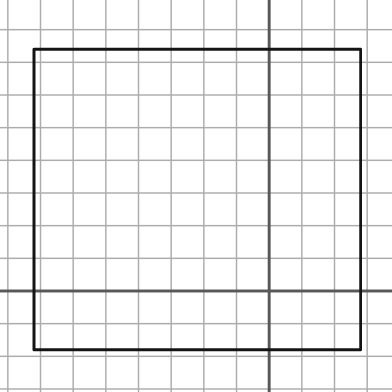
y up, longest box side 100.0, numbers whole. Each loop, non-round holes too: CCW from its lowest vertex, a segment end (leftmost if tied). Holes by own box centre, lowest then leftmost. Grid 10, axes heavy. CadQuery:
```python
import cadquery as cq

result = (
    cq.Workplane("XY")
    .moveTo(-72.0, -18.0)
    .lineTo(28.0, -18.0)
    .lineTo(28.0, 74.0)
    .lineTo(-72.0, 74.0)
    .close()
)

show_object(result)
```